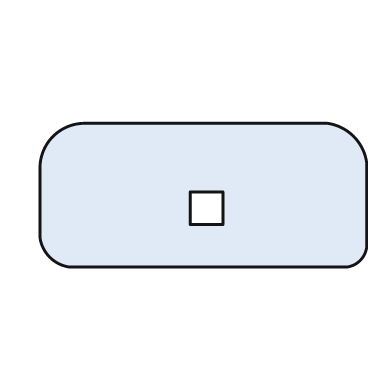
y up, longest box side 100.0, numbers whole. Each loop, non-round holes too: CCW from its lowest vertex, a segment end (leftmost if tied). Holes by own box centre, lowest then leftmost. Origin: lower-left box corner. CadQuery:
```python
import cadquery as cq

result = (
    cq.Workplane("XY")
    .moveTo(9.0, 0.0)
    .lineTo(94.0, 0.0)
    .threePointArc((98.0, 2.0), (100.0, 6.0))
    .lineTo(100.0, 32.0)
    .threePointArc((96.0, 40.0), (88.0, 44.0))
    .lineTo(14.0, 44.0)
    .threePointArc((4.0, 40.0), (0.0, 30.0))
    .lineTo(0.0, 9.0)
    .threePointArc((3.0, 3.0), (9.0, 0.0))
    .close()
    .moveTo(46.0, 13.0)
    .lineTo(56.0, 13.0)
    .lineTo(56.0, 23.0)
    .lineTo(46.0, 23.0)
    .close()
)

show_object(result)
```